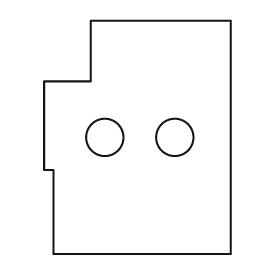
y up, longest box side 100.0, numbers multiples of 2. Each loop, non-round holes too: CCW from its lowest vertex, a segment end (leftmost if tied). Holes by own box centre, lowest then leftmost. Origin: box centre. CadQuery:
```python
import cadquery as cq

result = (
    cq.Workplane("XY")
    .moveTo(-36.0, -50.0)
    .lineTo(40.0, -50.0)
    .lineTo(40.0, 50.0)
    .lineTo(-20.0, 50.0)
    .lineTo(-20.0, 24.0)
    .lineTo(-40.0, 24.0)
    .lineTo(-40.0, -14.0)
    .lineTo(-36.0, -14.0)
    .close()
    .moveTo(-14.0, 0.0)
    .circle(8.0)
    .moveTo(16.0, 0.0)
    .circle(8.0)
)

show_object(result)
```